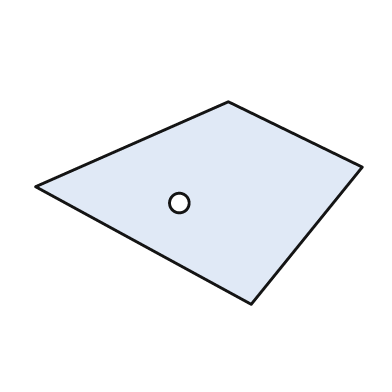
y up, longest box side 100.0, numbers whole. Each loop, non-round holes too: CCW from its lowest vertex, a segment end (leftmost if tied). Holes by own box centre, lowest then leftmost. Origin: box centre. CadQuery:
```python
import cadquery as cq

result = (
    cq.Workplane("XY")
    .moveTo(16.0, -31.0)
    .lineTo(50.0, 11.0)
    .lineTo(9.0, 31.0)
    .lineTo(-50.0, 5.0)
    .close()
    .moveTo(-6.0, 0.0)
    .circle(3.0)
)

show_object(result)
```